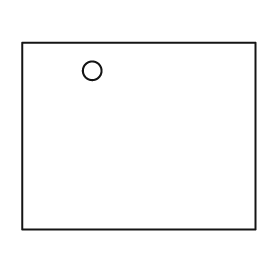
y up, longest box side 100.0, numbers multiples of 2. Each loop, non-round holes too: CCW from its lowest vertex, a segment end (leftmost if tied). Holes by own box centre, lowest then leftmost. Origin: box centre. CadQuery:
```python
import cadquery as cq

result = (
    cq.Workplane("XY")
    .moveTo(-50.0, -40.0)
    .lineTo(50.0, -40.0)
    .lineTo(50.0, 40.0)
    .lineTo(-50.0, 40.0)
    .close()
    .moveTo(-20.0, 28.0)
    .circle(4.0)
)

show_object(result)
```